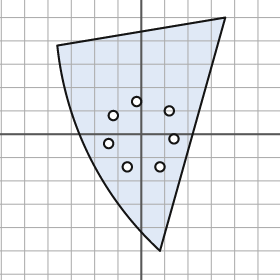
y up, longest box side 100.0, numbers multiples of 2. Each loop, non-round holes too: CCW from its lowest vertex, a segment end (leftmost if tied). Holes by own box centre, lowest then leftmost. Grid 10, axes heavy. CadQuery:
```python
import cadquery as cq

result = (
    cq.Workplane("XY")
    .moveTo(8.0, -50.0)
    .lineTo(36.0, 50.0)
    .lineTo(-36.0, 38.0)
    .threePointArc((-22.0, -10.0), (8.0, -50.0))
    .close()
    .moveTo(-6.0, -14.0)
    .circle(2.0)
    .moveTo(8.0, -14.0)
    .circle(2.0)
    .moveTo(-14.0, -4.0)
    .circle(2.0)
    .moveTo(14.0, -2.0)
    .circle(2.0)
    .moveTo(-12.0, 8.0)
    .circle(2.0)
    .moveTo(12.0, 10.0)
    .circle(2.0)
    .moveTo(-2.0, 14.0)
    .circle(2.0)
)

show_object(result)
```